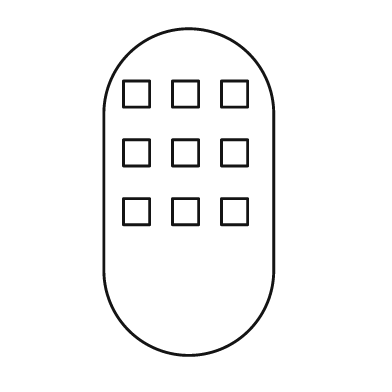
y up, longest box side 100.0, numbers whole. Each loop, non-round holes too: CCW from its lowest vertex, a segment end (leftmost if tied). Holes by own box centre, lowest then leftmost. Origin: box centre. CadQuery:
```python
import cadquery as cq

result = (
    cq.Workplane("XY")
    .moveTo(-26.0, -24.0)
    .threePointArc((0.0, -50.0), (26.0, -24.0))
    .lineTo(26.0, 24.0)
    .threePointArc((0.0, 50.0), (-26.0, 24.0))
    .close()
    .moveTo(-20.0, -10.0)
    .lineTo(-12.0, -10.0)
    .lineTo(-12.0, -2.0)
    .lineTo(-20.0, -2.0)
    .close()
    .moveTo(-5.0, -10.0)
    .lineTo(3.0, -10.0)
    .lineTo(3.0, -2.0)
    .lineTo(-5.0, -2.0)
    .close()
    .moveTo(10.0, -10.0)
    .lineTo(18.0, -10.0)
    .lineTo(18.0, -2.0)
    .lineTo(10.0, -2.0)
    .close()
    .moveTo(-20.0, 8.0)
    .lineTo(-12.0, 8.0)
    .lineTo(-12.0, 16.0)
    .lineTo(-20.0, 16.0)
    .close()
    .moveTo(-5.0, 8.0)
    .lineTo(3.0, 8.0)
    .lineTo(3.0, 16.0)
    .lineTo(-5.0, 16.0)
    .close()
    .moveTo(10.0, 8.0)
    .lineTo(18.0, 8.0)
    .lineTo(18.0, 16.0)
    .lineTo(10.0, 16.0)
    .close()
    .moveTo(-20.0, 26.0)
    .lineTo(-12.0, 26.0)
    .lineTo(-12.0, 34.0)
    .lineTo(-20.0, 34.0)
    .close()
    .moveTo(-5.0, 26.0)
    .lineTo(3.0, 26.0)
    .lineTo(3.0, 34.0)
    .lineTo(-5.0, 34.0)
    .close()
    .moveTo(10.0, 26.0)
    .lineTo(18.0, 26.0)
    .lineTo(18.0, 34.0)
    .lineTo(10.0, 34.0)
    .close()
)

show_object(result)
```